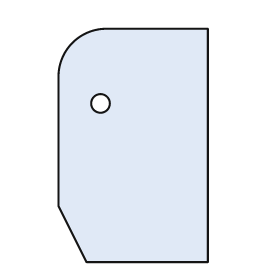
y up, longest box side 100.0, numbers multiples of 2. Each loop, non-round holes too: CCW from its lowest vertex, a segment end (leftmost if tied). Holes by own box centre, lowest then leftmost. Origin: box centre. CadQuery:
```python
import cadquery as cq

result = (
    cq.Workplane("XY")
    .moveTo(-20.0, -50.0)
    .lineTo(32.0, -50.0)
    .lineTo(32.0, 50.0)
    .lineTo(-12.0, 50.0)
    .threePointArc((-26.0, 44.0), (-32.0, 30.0))
    .lineTo(-32.0, -26.0)
    .close()
    .moveTo(-14.0, 18.0)
    .circle(4.0)
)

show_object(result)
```